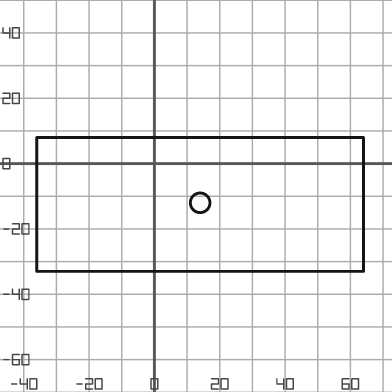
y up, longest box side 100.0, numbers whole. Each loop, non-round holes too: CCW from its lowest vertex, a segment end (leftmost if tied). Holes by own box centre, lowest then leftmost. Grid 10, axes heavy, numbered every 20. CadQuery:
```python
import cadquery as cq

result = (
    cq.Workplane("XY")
    .moveTo(-36.0, -33.0)
    .lineTo(64.0, -33.0)
    .lineTo(64.0, 8.0)
    .lineTo(-36.0, 8.0)
    .close()
    .moveTo(14.0, -12.0)
    .circle(3.0)
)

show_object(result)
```